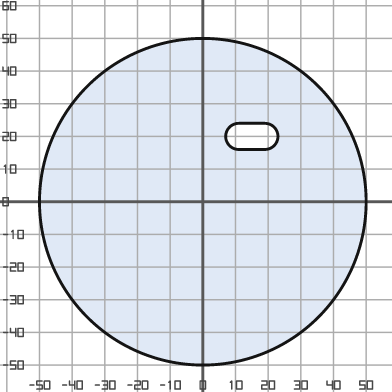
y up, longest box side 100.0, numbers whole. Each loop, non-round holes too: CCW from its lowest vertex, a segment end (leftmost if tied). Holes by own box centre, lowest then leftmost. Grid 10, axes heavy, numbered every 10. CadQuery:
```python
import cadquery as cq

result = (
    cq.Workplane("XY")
    .moveTo(0.0, 0.0)
    .circle(50.0)
    .moveTo(11.0, 16.0)
    .lineTo(19.0, 16.0)
    .threePointArc((23.0, 20.0), (19.0, 24.0))
    .lineTo(11.0, 24.0)
    .threePointArc((7.0, 20.0), (11.0, 16.0))
    .close()
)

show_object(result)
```